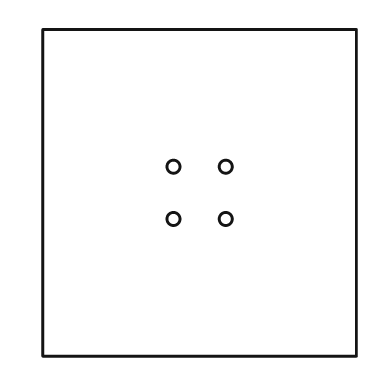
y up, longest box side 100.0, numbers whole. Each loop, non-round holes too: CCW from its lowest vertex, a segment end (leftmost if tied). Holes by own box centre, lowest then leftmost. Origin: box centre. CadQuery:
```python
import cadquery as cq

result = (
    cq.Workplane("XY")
    .moveTo(-48.0, -50.0)
    .lineTo(48.0, -50.0)
    .lineTo(48.0, 50.0)
    .lineTo(-48.0, 50.0)
    .close()
    .moveTo(-8.0, -8.0)
    .circle(2.0)
    .moveTo(8.0, -8.0)
    .circle(2.0)
    .moveTo(-8.0, 8.0)
    .circle(2.0)
    .moveTo(8.0, 8.0)
    .circle(2.0)
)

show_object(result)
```